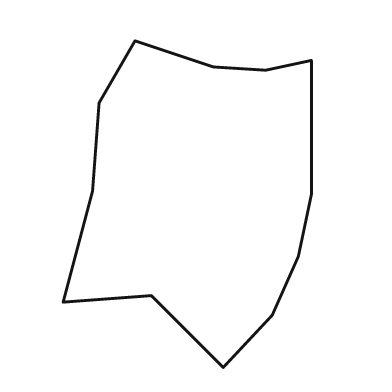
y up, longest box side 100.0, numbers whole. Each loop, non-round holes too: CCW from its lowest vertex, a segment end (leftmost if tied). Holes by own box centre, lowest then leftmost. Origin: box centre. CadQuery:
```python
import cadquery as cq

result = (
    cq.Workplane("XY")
    .moveTo(11.0, -50.0)
    .lineTo(26.0, -34.0)
    .lineTo(34.0, -16.0)
    .lineTo(38.0, 3.0)
    .lineTo(38.0, 44.0)
    .lineTo(24.0, 41.0)
    .lineTo(8.0, 42.0)
    .lineTo(-16.0, 50.0)
    .lineTo(-27.0, 31.0)
    .lineTo(-29.0, 4.0)
    .lineTo(-38.0, -30.0)
    .lineTo(-11.0, -28.0)
    .close()
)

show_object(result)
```